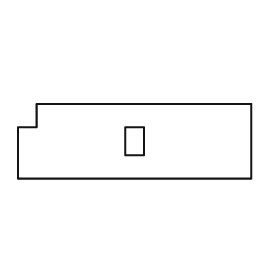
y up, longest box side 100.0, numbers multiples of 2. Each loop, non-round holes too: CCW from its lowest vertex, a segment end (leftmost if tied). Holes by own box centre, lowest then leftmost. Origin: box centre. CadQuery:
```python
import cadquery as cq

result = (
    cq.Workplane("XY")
    .moveTo(-50.0, -16.0)
    .lineTo(50.0, -16.0)
    .lineTo(50.0, 16.0)
    .lineTo(-42.0, 16.0)
    .lineTo(-42.0, 6.0)
    .lineTo(-50.0, 6.0)
    .close()
    .moveTo(-4.0, -6.0)
    .lineTo(4.0, -6.0)
    .lineTo(4.0, 6.0)
    .lineTo(-4.0, 6.0)
    .close()
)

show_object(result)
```